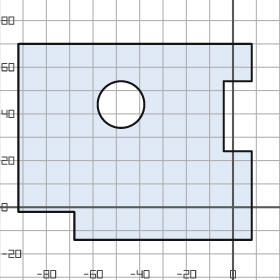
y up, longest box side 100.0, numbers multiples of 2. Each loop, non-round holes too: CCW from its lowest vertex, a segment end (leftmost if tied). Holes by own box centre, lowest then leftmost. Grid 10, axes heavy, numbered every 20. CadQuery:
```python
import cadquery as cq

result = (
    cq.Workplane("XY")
    .moveTo(-68.0, -14.0)
    .lineTo(8.0, -14.0)
    .lineTo(8.0, 24.0)
    .lineTo(-4.0, 24.0)
    .lineTo(-4.0, 54.0)
    .lineTo(8.0, 54.0)
    .lineTo(8.0, 70.0)
    .lineTo(-92.0, 70.0)
    .lineTo(-92.0, -2.0)
    .lineTo(-68.0, -2.0)
    .close()
    .moveTo(-48.0, 44.0)
    .circle(10.0)
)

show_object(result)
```